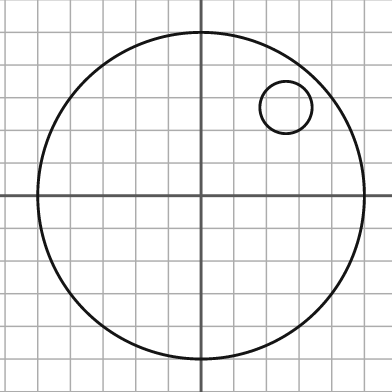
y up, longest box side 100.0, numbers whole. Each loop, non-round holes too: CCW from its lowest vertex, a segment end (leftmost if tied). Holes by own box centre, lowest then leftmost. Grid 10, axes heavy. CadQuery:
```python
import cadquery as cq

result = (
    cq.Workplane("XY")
    .moveTo(0.0, 0.0)
    .circle(50.0)
    .moveTo(26.0, 27.0)
    .circle(8.0)
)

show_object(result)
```